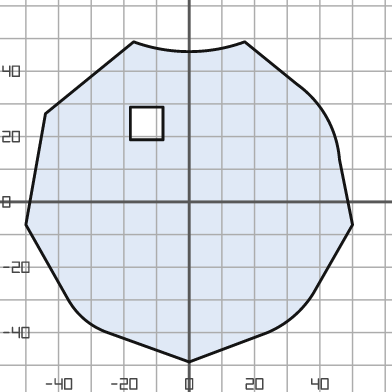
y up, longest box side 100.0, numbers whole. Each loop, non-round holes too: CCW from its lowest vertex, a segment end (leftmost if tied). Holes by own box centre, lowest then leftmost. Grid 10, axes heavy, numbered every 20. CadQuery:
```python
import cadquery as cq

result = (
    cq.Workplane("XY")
    .moveTo(0.0, -49.0)
    .lineTo(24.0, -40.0)
    .threePointArc((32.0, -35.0), (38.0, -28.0))
    .lineTo(50.0, -7.0)
    .lineTo(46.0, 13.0)
    .threePointArc((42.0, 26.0), (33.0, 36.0))
    .lineTo(17.0, 49.0)
    .threePointArc((0.0, 46.0), (-17.0, 49.0))
    .lineTo(-44.0, 27.0)
    .lineTo(-50.0, -7.0)
    .lineTo(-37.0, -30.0)
    .threePointArc((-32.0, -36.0), (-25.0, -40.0))
    .close()
    .moveTo(-18.0, 19.0)
    .lineTo(-8.0, 19.0)
    .lineTo(-8.0, 29.0)
    .lineTo(-18.0, 29.0)
    .close()
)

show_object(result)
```